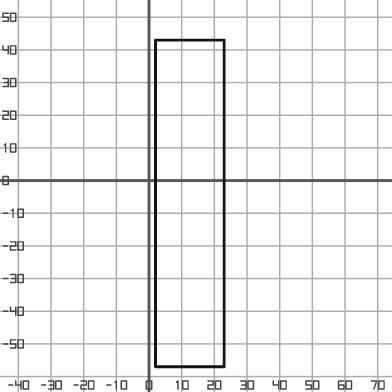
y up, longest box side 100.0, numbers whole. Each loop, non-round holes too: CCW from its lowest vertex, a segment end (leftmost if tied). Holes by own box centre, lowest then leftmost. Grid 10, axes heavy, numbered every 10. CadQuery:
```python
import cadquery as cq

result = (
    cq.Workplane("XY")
    .moveTo(2.0, -57.0)
    .lineTo(23.0, -57.0)
    .lineTo(23.0, 43.0)
    .lineTo(2.0, 43.0)
    .close()
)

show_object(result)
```